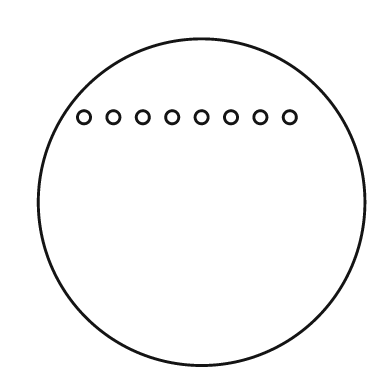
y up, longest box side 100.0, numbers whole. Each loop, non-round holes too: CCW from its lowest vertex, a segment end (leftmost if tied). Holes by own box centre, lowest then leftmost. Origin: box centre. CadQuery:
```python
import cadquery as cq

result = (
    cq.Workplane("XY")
    .moveTo(0.0, 0.0)
    .circle(50.0)
    .moveTo(-36.0, 26.0)
    .circle(2.0)
    .moveTo(-27.0, 26.0)
    .circle(2.0)
    .moveTo(-18.0, 26.0)
    .circle(2.0)
    .moveTo(-9.0, 26.0)
    .circle(2.0)
    .moveTo(0.0, 26.0)
    .circle(2.0)
    .moveTo(9.0, 26.0)
    .circle(2.0)
    .moveTo(18.0, 26.0)
    .circle(2.0)
    .moveTo(27.0, 26.0)
    .circle(2.0)
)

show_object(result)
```